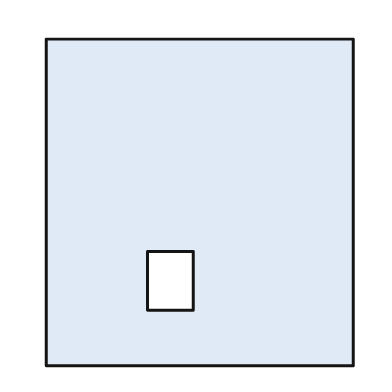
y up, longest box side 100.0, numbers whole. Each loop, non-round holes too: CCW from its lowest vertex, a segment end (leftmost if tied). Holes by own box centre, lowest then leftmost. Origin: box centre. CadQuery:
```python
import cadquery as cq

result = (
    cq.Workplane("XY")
    .moveTo(-47.0, -50.0)
    .lineTo(47.0, -50.0)
    .lineTo(47.0, 50.0)
    .lineTo(-47.0, 50.0)
    .close()
    .moveTo(-16.0, -33.0)
    .lineTo(-2.0, -33.0)
    .lineTo(-2.0, -15.0)
    .lineTo(-16.0, -15.0)
    .close()
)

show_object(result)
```